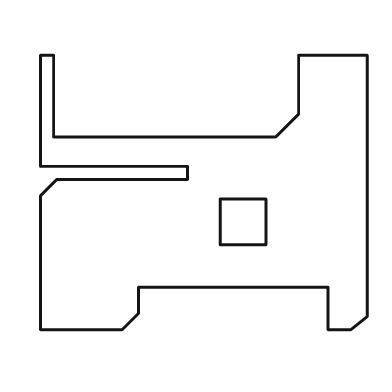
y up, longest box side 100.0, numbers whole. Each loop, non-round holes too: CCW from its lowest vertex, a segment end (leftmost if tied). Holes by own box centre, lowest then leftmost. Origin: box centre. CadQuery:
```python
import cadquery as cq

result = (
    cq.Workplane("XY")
    .moveTo(-50.0, -42.0)
    .lineTo(-25.0, -42.0)
    .lineTo(-20.0, -37.0)
    .lineTo(-20.0, -29.0)
    .lineTo(38.0, -29.0)
    .lineTo(38.0, -42.0)
    .lineTo(45.0, -42.0)
    .lineTo(50.0, -38.0)
    .lineTo(50.0, 42.0)
    .lineTo(29.0, 42.0)
    .lineTo(29.0, 24.0)
    .lineTo(22.0, 17.0)
    .lineTo(-46.0, 17.0)
    .lineTo(-46.0, 42.0)
    .lineTo(-50.0, 42.0)
    .lineTo(-50.0, 8.0)
    .lineTo(-5.0, 8.0)
    .lineTo(-5.0, 4.0)
    .lineTo(-45.0, 4.0)
    .lineTo(-50.0, -1.0)
    .close()
    .moveTo(5.0, -16.0)
    .lineTo(19.0, -16.0)
    .lineTo(19.0, -2.0)
    .lineTo(5.0, -2.0)
    .close()
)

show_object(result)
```